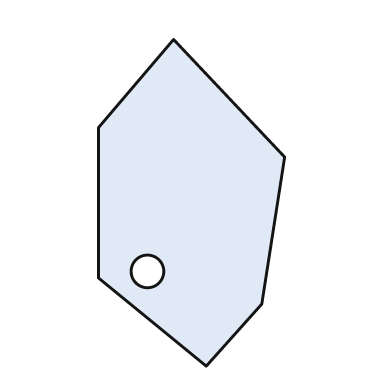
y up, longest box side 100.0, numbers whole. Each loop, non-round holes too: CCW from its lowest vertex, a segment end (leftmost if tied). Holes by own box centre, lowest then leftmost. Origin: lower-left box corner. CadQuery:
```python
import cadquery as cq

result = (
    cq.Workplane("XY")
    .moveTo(33.0, 0.0)
    .lineTo(50.0, 19.0)
    .lineTo(57.0, 64.0)
    .lineTo(23.0, 100.0)
    .lineTo(0.0, 73.0)
    .lineTo(0.0, 27.0)
    .close()
    .moveTo(15.0, 29.0)
    .circle(5.0)
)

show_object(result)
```